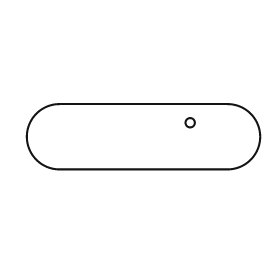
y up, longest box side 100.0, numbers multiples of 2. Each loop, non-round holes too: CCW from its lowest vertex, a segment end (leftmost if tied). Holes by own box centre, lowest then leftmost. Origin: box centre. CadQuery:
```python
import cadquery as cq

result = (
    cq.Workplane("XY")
    .moveTo(-36.0, -14.0)
    .lineTo(36.0, -14.0)
    .threePointArc((50.0, 0.0), (36.0, 14.0))
    .lineTo(-36.0, 14.0)
    .threePointArc((-50.0, 0.0), (-36.0, -14.0))
    .close()
    .moveTo(20.0, 6.0)
    .circle(2.0)
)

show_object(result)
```